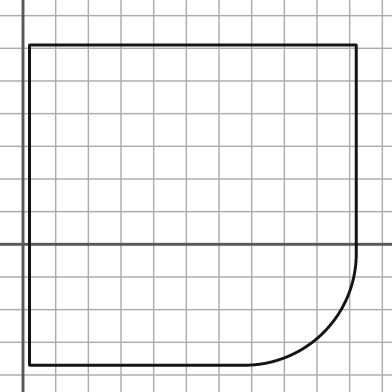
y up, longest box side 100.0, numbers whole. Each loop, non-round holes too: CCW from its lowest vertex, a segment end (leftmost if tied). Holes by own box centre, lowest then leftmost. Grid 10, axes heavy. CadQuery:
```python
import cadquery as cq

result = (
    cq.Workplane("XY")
    .moveTo(2.0, -37.0)
    .lineTo(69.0, -37.0)
    .threePointArc((92.0, -27.0), (102.0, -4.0))
    .lineTo(102.0, 61.0)
    .lineTo(2.0, 61.0)
    .close()
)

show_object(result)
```